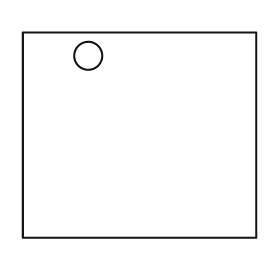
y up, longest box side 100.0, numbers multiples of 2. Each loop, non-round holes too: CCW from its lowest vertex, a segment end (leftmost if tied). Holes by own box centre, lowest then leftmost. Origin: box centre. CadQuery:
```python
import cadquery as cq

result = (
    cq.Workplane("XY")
    .moveTo(-50.0, -44.0)
    .lineTo(50.0, -44.0)
    .lineTo(50.0, 44.0)
    .lineTo(-50.0, 44.0)
    .close()
    .moveTo(-22.0, 34.0)
    .circle(6.0)
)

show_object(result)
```